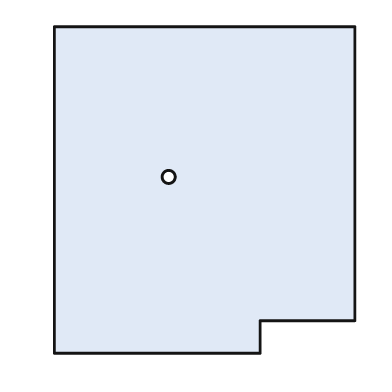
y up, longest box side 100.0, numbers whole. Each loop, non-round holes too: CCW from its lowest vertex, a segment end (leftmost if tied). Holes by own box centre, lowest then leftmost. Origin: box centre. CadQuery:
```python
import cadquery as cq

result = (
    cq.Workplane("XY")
    .moveTo(-46.0, -50.0)
    .lineTo(17.0, -50.0)
    .lineTo(17.0, -40.0)
    .lineTo(46.0, -40.0)
    .lineTo(46.0, 50.0)
    .lineTo(-46.0, 50.0)
    .close()
    .moveTo(-11.0, 4.0)
    .circle(2.0)
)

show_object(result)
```